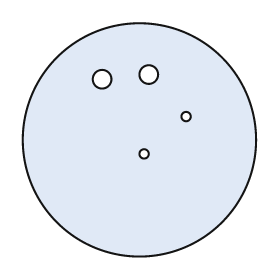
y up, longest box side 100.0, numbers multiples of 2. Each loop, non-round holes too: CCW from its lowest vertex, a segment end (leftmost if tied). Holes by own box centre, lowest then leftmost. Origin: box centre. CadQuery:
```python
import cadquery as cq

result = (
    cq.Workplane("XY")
    .moveTo(0.0, 0.0)
    .circle(50.0)
    .moveTo(2.0, -6.0)
    .circle(2.0)
    .moveTo(20.0, 10.0)
    .circle(2.0)
    .moveTo(-16.0, 26.0)
    .circle(4.0)
    .moveTo(4.0, 28.0)
    .circle(4.0)
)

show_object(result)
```